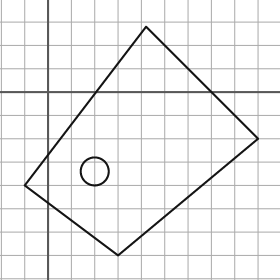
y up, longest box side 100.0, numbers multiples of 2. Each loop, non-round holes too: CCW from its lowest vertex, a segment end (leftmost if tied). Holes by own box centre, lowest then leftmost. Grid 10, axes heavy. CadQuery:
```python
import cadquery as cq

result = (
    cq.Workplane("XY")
    .moveTo(30.0, -70.0)
    .lineTo(90.0, -20.0)
    .lineTo(42.0, 28.0)
    .lineTo(-10.0, -40.0)
    .close()
    .moveTo(20.0, -34.0)
    .circle(6.0)
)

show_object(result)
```